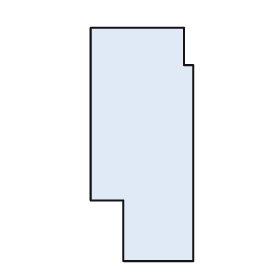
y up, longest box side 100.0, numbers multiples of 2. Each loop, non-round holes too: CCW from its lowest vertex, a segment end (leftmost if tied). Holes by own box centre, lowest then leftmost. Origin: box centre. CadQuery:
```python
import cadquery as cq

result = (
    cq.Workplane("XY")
    .moveTo(-8.0, -50.0)
    .lineTo(22.0, -50.0)
    .lineTo(22.0, 34.0)
    .lineTo(18.0, 34.0)
    .lineTo(18.0, 50.0)
    .lineTo(-22.0, 50.0)
    .lineTo(-22.0, -24.0)
    .lineTo(-8.0, -24.0)
    .close()
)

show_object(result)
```